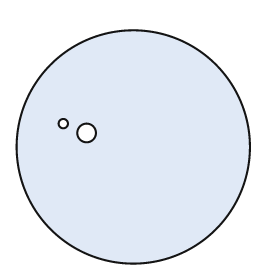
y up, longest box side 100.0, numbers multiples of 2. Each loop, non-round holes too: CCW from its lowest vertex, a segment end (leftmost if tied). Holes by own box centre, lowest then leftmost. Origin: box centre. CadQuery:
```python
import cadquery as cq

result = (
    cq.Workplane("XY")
    .moveTo(0.0, 0.0)
    .circle(50.0)
    .moveTo(-20.0, 6.0)
    .circle(4.0)
    .moveTo(-30.0, 10.0)
    .circle(2.0)
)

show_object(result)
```